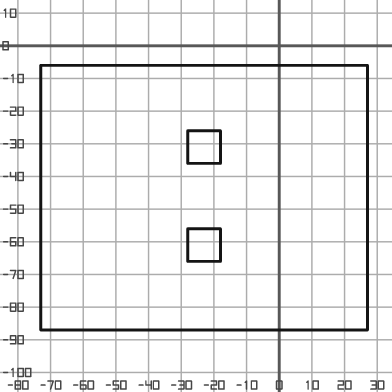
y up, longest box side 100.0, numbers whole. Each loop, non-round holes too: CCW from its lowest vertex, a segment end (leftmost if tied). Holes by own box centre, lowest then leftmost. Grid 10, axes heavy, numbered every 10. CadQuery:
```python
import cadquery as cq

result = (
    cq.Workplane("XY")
    .moveTo(-73.0, -87.0)
    .lineTo(27.0, -87.0)
    .lineTo(27.0, -6.0)
    .lineTo(-73.0, -6.0)
    .close()
    .moveTo(-28.0, -66.0)
    .lineTo(-18.0, -66.0)
    .lineTo(-18.0, -56.0)
    .lineTo(-28.0, -56.0)
    .close()
    .moveTo(-28.0, -36.0)
    .lineTo(-18.0, -36.0)
    .lineTo(-18.0, -26.0)
    .lineTo(-28.0, -26.0)
    .close()
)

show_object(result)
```